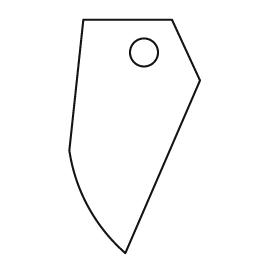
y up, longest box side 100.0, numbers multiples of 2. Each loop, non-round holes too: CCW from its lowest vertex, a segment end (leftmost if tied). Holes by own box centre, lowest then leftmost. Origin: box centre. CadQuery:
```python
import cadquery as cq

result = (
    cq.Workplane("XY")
    .moveTo(-4.0, -50.0)
    .lineTo(28.0, 24.0)
    .lineTo(16.0, 50.0)
    .lineTo(-22.0, 50.0)
    .lineTo(-28.0, -6.0)
    .threePointArc((-20.0, -30.0), (-4.0, -50.0))
    .close()
    .moveTo(4.0, 36.0)
    .circle(6.0)
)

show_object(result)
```